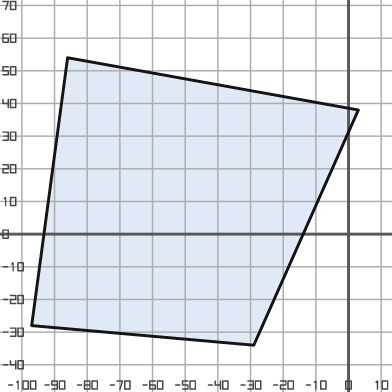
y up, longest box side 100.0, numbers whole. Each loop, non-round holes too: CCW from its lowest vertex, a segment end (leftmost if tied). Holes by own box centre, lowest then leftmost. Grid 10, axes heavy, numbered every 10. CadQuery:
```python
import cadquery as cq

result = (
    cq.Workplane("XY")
    .moveTo(-29.0, -34.0)
    .lineTo(3.0, 38.0)
    .lineTo(-86.0, 54.0)
    .lineTo(-97.0, -28.0)
    .close()
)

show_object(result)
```